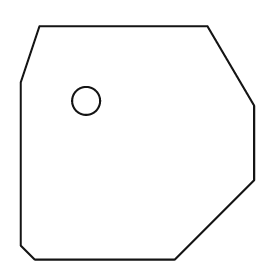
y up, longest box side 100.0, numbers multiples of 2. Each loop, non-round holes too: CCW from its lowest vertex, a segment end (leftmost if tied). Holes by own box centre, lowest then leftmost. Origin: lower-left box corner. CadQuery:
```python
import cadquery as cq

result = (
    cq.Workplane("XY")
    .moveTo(6.0, 0.0)
    .lineTo(66.0, 0.0)
    .lineTo(100.0, 34.0)
    .lineTo(100.0, 66.0)
    .lineTo(80.0, 100.0)
    .lineTo(8.0, 100.0)
    .lineTo(0.0, 76.0)
    .lineTo(0.0, 6.0)
    .close()
    .moveTo(28.0, 68.0)
    .circle(6.0)
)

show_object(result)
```